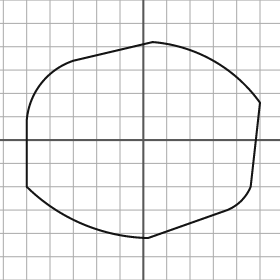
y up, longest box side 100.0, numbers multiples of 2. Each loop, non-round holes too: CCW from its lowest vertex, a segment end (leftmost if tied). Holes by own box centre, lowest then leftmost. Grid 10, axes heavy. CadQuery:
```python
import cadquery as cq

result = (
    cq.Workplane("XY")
    .moveTo(2.0, -42.0)
    .lineTo(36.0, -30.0)
    .threePointArc((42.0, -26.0), (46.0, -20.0))
    .lineTo(50.0, 16.0)
    .threePointArc((30.0, 34.0), (4.0, 42.0))
    .lineTo(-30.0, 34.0)
    .threePointArc((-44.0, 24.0), (-50.0, 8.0))
    .lineTo(-50.0, -20.0)
    .threePointArc((-26.0, -36.0), (2.0, -42.0))
    .close()
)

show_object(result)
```